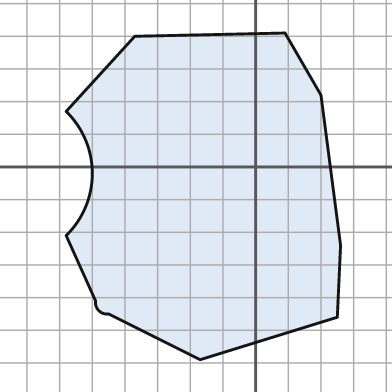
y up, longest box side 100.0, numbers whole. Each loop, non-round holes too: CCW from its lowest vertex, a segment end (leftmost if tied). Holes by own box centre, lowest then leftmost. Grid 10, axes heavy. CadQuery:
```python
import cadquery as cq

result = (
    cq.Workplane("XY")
    .moveTo(-17.0, -59.0)
    .lineTo(25.0, -46.0)
    .lineTo(26.0, -24.0)
    .lineTo(20.0, 22.0)
    .lineTo(9.0, 41.0)
    .lineTo(-37.0, 40.0)
    .lineTo(-58.0, 17.0)
    .threePointArc((-50.0, -2.0), (-58.0, -21.0))
    .lineTo(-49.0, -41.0)
    .threePointArc((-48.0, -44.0), (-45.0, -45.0))
    .close()
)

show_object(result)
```